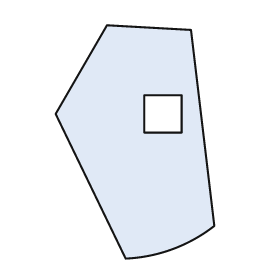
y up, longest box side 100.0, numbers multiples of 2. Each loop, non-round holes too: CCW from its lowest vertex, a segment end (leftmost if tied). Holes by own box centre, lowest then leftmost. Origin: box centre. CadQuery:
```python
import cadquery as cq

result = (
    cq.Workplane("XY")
    .moveTo(-4.0, -50.0)
    .threePointArc((16.0, -46.0), (34.0, -36.0))
    .lineTo(24.0, 48.0)
    .lineTo(-12.0, 50.0)
    .lineTo(-34.0, 12.0)
    .close()
    .moveTo(4.0, 4.0)
    .lineTo(20.0, 4.0)
    .lineTo(20.0, 20.0)
    .lineTo(4.0, 20.0)
    .close()
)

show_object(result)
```